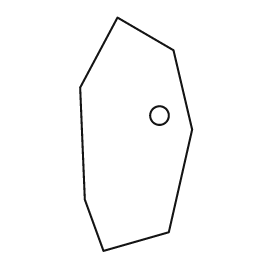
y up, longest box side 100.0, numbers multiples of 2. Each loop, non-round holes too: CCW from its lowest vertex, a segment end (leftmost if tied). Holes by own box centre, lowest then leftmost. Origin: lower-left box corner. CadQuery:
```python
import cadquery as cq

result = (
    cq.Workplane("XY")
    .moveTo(10.0, 0.0)
    .lineTo(38.0, 8.0)
    .lineTo(48.0, 52.0)
    .lineTo(40.0, 86.0)
    .lineTo(16.0, 100.0)
    .lineTo(0.0, 70.0)
    .lineTo(2.0, 22.0)
    .close()
    .moveTo(34.0, 58.0)
    .circle(4.0)
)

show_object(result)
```